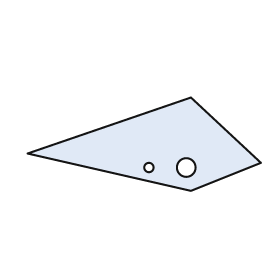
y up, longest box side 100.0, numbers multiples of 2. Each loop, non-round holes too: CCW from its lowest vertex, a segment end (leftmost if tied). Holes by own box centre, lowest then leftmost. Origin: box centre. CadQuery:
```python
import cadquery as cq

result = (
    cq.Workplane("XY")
    .moveTo(20.0, -20.0)
    .lineTo(50.0, -8.0)
    .lineTo(20.0, 20.0)
    .lineTo(-50.0, -4.0)
    .close()
    .moveTo(2.0, -10.0)
    .circle(2.0)
    .moveTo(18.0, -10.0)
    .circle(4.0)
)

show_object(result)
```